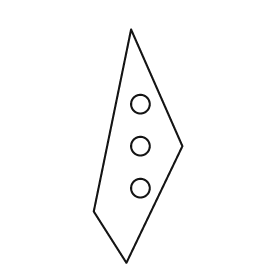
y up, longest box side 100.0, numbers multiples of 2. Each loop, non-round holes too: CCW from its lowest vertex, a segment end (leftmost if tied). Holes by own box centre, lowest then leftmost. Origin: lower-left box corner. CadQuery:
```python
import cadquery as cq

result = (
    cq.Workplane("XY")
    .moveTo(14.0, 0.0)
    .lineTo(38.0, 50.0)
    .lineTo(16.0, 100.0)
    .lineTo(0.0, 22.0)
    .close()
    .moveTo(20.0, 32.0)
    .circle(4.0)
    .moveTo(20.0, 50.0)
    .circle(4.0)
    .moveTo(20.0, 68.0)
    .circle(4.0)
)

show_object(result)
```